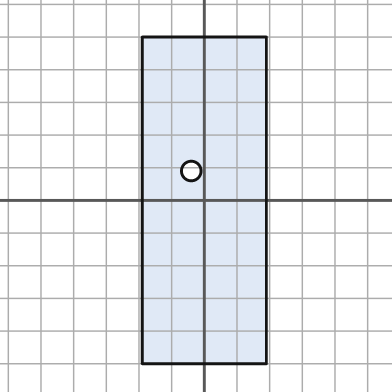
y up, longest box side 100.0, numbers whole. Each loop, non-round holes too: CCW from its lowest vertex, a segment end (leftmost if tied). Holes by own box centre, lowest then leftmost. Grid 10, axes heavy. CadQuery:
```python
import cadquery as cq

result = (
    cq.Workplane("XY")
    .moveTo(-19.0, -50.0)
    .lineTo(19.0, -50.0)
    .lineTo(19.0, 50.0)
    .lineTo(-19.0, 50.0)
    .close()
    .moveTo(-4.0, 9.0)
    .circle(3.0)
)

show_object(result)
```